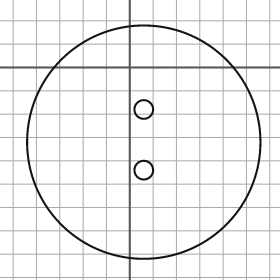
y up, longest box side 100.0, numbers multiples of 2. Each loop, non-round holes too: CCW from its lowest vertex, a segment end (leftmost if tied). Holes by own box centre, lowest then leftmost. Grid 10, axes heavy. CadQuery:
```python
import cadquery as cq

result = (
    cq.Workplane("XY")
    .moveTo(6.0, -32.0)
    .circle(50.0)
    .moveTo(6.0, -44.0)
    .circle(4.0)
    .moveTo(6.0, -18.0)
    .circle(4.0)
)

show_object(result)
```